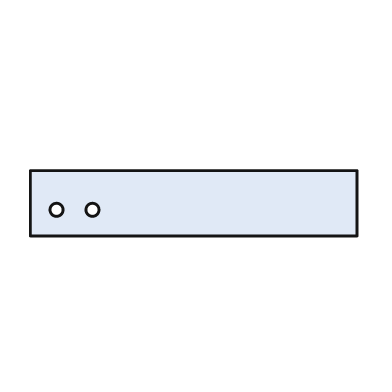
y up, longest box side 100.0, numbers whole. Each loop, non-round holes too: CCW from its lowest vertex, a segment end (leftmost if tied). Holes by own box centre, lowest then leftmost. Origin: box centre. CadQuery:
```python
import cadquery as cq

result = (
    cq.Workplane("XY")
    .moveTo(-50.0, -10.0)
    .lineTo(50.0, -10.0)
    .lineTo(50.0, 10.0)
    .lineTo(-50.0, 10.0)
    .close()
    .moveTo(-42.0, -2.0)
    .circle(2.0)
    .moveTo(-31.0, -2.0)
    .circle(2.0)
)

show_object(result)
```